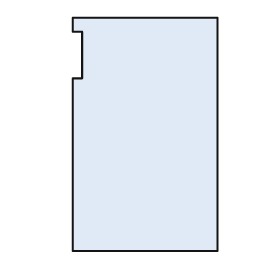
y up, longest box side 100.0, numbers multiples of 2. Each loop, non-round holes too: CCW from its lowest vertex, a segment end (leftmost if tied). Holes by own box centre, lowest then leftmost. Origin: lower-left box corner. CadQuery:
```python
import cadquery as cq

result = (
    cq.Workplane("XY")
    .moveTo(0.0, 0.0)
    .lineTo(62.0, 0.0)
    .lineTo(62.0, 100.0)
    .lineTo(0.0, 100.0)
    .lineTo(0.0, 94.0)
    .lineTo(4.0, 94.0)
    .lineTo(4.0, 74.0)
    .lineTo(0.0, 74.0)
    .close()
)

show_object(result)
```